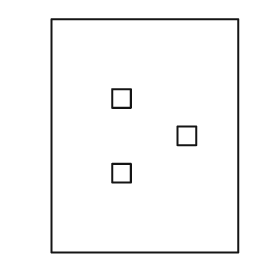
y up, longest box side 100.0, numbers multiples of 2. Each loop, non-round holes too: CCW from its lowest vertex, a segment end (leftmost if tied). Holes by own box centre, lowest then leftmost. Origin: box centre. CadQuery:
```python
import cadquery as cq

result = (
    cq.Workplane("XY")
    .moveTo(-40.0, -50.0)
    .lineTo(40.0, -50.0)
    .lineTo(40.0, 50.0)
    .lineTo(-40.0, 50.0)
    .close()
    .moveTo(-14.0, -20.0)
    .lineTo(-6.0, -20.0)
    .lineTo(-6.0, -12.0)
    .lineTo(-14.0, -12.0)
    .close()
    .moveTo(14.0, -4.0)
    .lineTo(22.0, -4.0)
    .lineTo(22.0, 4.0)
    .lineTo(14.0, 4.0)
    .close()
    .moveTo(-14.0, 12.0)
    .lineTo(-6.0, 12.0)
    .lineTo(-6.0, 20.0)
    .lineTo(-14.0, 20.0)
    .close()
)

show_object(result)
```